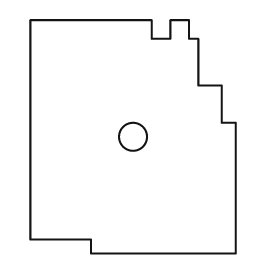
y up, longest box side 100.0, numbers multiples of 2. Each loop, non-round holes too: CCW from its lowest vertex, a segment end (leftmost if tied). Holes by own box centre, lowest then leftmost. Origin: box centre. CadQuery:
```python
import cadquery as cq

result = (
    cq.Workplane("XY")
    .moveTo(-18.0, -50.0)
    .lineTo(44.0, -50.0)
    .lineTo(44.0, 6.0)
    .lineTo(38.0, 6.0)
    .lineTo(38.0, 22.0)
    .lineTo(28.0, 22.0)
    .lineTo(28.0, 42.0)
    .lineTo(24.0, 42.0)
    .lineTo(24.0, 50.0)
    .lineTo(16.0, 50.0)
    .lineTo(16.0, 42.0)
    .lineTo(8.0, 42.0)
    .lineTo(8.0, 50.0)
    .lineTo(-44.0, 50.0)
    .lineTo(-44.0, -44.0)
    .lineTo(-18.0, -44.0)
    .close()
    .moveTo(0.0, 0.0)
    .circle(6.0)
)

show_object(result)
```